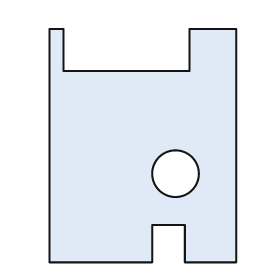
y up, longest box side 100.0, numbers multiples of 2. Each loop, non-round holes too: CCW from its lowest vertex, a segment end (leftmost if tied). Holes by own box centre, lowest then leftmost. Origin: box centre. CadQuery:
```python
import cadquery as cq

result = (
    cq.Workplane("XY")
    .moveTo(-40.0, -50.0)
    .lineTo(4.0, -50.0)
    .lineTo(4.0, -34.0)
    .lineTo(18.0, -34.0)
    .lineTo(18.0, -50.0)
    .lineTo(40.0, -50.0)
    .lineTo(40.0, 50.0)
    .lineTo(20.0, 50.0)
    .lineTo(20.0, 32.0)
    .lineTo(-34.0, 32.0)
    .lineTo(-34.0, 50.0)
    .lineTo(-40.0, 50.0)
    .close()
    .moveTo(14.0, -12.0)
    .circle(10.0)
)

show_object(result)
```